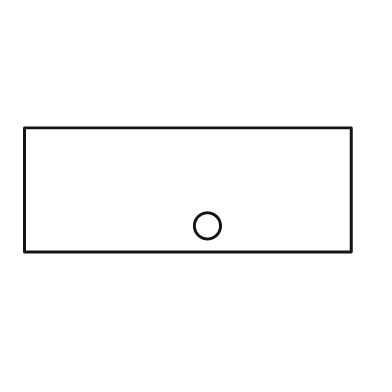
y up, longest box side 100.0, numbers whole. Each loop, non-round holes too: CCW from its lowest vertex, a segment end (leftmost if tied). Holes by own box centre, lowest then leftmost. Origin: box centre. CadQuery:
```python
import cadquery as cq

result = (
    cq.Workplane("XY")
    .moveTo(-50.0, -19.0)
    .lineTo(50.0, -19.0)
    .lineTo(50.0, 19.0)
    .lineTo(-50.0, 19.0)
    .close()
    .moveTo(6.0, -11.0)
    .circle(4.0)
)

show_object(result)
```